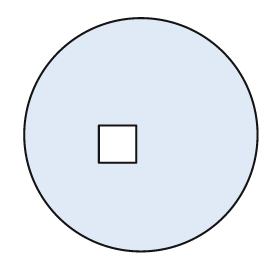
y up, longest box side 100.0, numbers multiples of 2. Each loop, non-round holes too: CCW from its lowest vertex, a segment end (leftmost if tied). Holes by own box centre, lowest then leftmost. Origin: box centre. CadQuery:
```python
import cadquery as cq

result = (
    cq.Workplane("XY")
    .moveTo(0.0, 0.0)
    .circle(50.0)
    .moveTo(-18.0, -12.0)
    .lineTo(-2.0, -12.0)
    .lineTo(-2.0, 4.0)
    .lineTo(-18.0, 4.0)
    .close()
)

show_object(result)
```